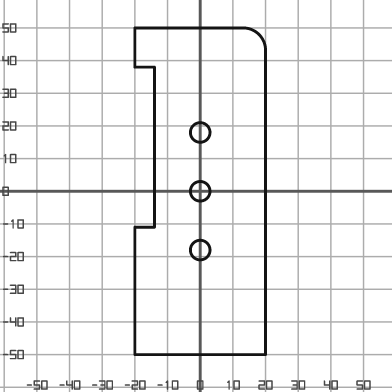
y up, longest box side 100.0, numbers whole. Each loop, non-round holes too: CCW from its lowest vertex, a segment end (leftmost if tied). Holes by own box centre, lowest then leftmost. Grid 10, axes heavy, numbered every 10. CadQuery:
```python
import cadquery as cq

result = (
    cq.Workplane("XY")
    .moveTo(-20.0, -50.0)
    .lineTo(20.0, -50.0)
    .lineTo(20.0, 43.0)
    .threePointArc((18.0, 48.0), (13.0, 50.0))
    .lineTo(-20.0, 50.0)
    .lineTo(-20.0, 38.0)
    .lineTo(-14.0, 38.0)
    .lineTo(-14.0, -11.0)
    .lineTo(-20.0, -11.0)
    .close()
    .moveTo(0.0, -18.0)
    .circle(3.0)
    .moveTo(0.0, 0.0)
    .circle(3.0)
    .moveTo(0.0, 18.0)
    .circle(3.0)
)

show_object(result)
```